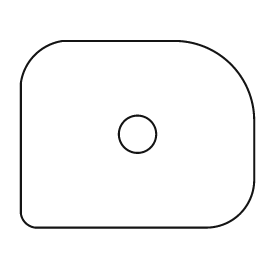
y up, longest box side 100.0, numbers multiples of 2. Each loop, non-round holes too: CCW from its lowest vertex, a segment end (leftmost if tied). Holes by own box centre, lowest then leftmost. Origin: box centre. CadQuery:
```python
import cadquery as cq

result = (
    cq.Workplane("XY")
    .moveTo(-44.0, -40.0)
    .lineTo(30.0, -40.0)
    .threePointArc((44.0, -34.0), (50.0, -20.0))
    .lineTo(50.0, 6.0)
    .threePointArc((40.0, 30.0), (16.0, 40.0))
    .lineTo(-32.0, 40.0)
    .threePointArc((-44.0, 34.0), (-50.0, 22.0))
    .lineTo(-50.0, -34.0)
    .threePointArc((-48.0, -38.0), (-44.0, -40.0))
    .close()
    .moveTo(0.0, 0.0)
    .circle(8.0)
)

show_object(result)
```